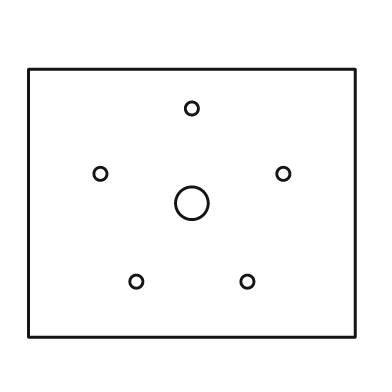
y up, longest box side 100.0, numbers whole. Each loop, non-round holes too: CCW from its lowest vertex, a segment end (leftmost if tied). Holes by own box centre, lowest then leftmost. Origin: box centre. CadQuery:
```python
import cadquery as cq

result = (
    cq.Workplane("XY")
    .moveTo(-50.0, -41.0)
    .lineTo(50.0, -41.0)
    .lineTo(50.0, 41.0)
    .lineTo(-50.0, 41.0)
    .close()
    .moveTo(-17.0, -24.0)
    .circle(2.0)
    .moveTo(17.0, -24.0)
    .circle(2.0)
    .moveTo(0.0, 0.0)
    .circle(5.0)
    .moveTo(-28.0, 9.0)
    .circle(2.0)
    .moveTo(28.0, 9.0)
    .circle(2.0)
    .moveTo(0.0, 29.0)
    .circle(2.0)
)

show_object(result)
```